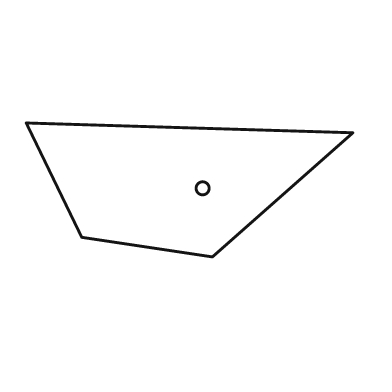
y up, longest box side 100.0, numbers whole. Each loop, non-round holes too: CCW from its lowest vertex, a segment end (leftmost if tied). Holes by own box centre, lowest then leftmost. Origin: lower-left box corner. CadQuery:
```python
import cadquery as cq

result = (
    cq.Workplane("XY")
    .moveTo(57.0, 0.0)
    .lineTo(100.0, 38.0)
    .lineTo(0.0, 41.0)
    .lineTo(17.0, 6.0)
    .close()
    .moveTo(54.0, 21.0)
    .circle(2.0)
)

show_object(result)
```